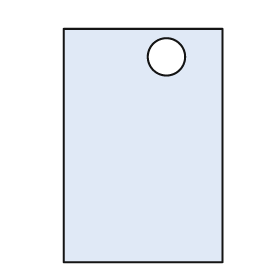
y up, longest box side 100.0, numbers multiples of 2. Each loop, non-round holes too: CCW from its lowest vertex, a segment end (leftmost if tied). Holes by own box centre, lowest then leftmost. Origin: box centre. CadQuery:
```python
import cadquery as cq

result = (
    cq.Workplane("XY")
    .moveTo(-34.0, -50.0)
    .lineTo(34.0, -50.0)
    .lineTo(34.0, 50.0)
    .lineTo(-34.0, 50.0)
    .close()
    .moveTo(10.0, 38.0)
    .circle(8.0)
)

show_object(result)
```